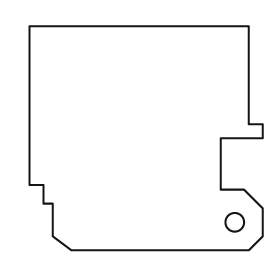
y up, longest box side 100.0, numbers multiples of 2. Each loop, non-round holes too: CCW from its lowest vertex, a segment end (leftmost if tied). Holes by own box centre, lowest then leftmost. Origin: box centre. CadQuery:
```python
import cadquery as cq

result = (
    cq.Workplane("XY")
    .moveTo(-32.0, -48.0)
    .lineTo(44.0, -48.0)
    .lineTo(50.0, -42.0)
    .lineTo(50.0, -30.0)
    .lineTo(42.0, -22.0)
    .lineTo(32.0, -22.0)
    .lineTo(32.0, 0.0)
    .lineTo(50.0, 0.0)
    .lineTo(50.0, 6.0)
    .lineTo(44.0, 6.0)
    .lineTo(44.0, 48.0)
    .lineTo(-50.0, 48.0)
    .lineTo(-50.0, -20.0)
    .lineTo(-44.0, -20.0)
    .lineTo(-44.0, -28.0)
    .lineTo(-40.0, -28.0)
    .lineTo(-40.0, -42.0)
    .close()
    .moveTo(38.0, -36.0)
    .circle(4.0)
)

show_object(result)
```